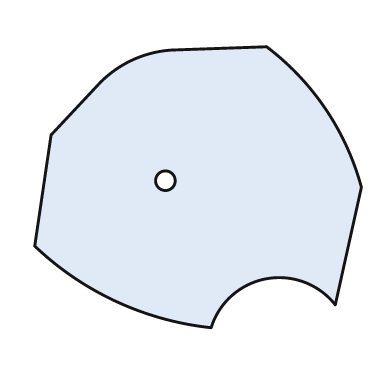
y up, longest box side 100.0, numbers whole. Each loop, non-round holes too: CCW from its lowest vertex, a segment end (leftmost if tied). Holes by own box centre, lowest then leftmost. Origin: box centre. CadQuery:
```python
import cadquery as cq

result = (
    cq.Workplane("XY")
    .moveTo(4.0, -43.0)
    .threePointArc((21.0, -28.0), (42.0, -36.0))
    .lineTo(50.0, 0.0)
    .threePointArc((39.0, 24.0), (21.0, 43.0))
    .lineTo(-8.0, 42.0)
    .threePointArc((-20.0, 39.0), (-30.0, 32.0))
    .lineTo(-45.0, 16.0)
    .lineTo(-50.0, -18.0)
    .threePointArc((-25.0, -35.0), (4.0, -43.0))
    .close()
    .moveTo(-10.0, 2.0)
    .circle(3.0)
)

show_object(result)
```